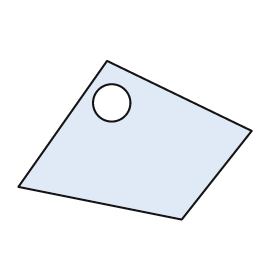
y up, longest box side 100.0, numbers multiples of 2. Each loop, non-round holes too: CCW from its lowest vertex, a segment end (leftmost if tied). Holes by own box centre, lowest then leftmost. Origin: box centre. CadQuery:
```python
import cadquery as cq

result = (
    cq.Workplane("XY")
    .moveTo(20.0, -34.0)
    .lineTo(50.0, 4.0)
    .lineTo(-12.0, 34.0)
    .lineTo(-50.0, -20.0)
    .close()
    .moveTo(-10.0, 16.0)
    .circle(8.0)
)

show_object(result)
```